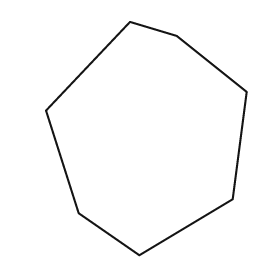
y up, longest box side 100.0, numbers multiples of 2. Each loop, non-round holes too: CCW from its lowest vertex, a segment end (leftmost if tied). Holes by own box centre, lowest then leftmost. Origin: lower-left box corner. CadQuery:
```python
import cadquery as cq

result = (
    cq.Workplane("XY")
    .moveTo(40.0, 0.0)
    .lineTo(80.0, 24.0)
    .lineTo(86.0, 70.0)
    .lineTo(56.0, 94.0)
    .lineTo(36.0, 100.0)
    .lineTo(0.0, 62.0)
    .lineTo(14.0, 18.0)
    .close()
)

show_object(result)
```